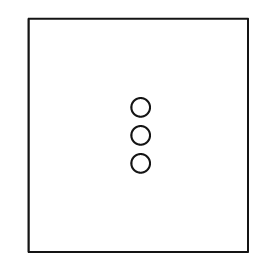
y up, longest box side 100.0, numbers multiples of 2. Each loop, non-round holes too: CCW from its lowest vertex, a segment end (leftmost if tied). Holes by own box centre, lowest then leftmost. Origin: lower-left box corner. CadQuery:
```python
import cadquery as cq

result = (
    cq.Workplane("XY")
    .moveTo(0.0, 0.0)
    .lineTo(94.0, 0.0)
    .lineTo(94.0, 100.0)
    .lineTo(0.0, 100.0)
    .close()
    .moveTo(48.0, 38.0)
    .circle(4.0)
    .moveTo(48.0, 50.0)
    .circle(4.0)
    .moveTo(48.0, 62.0)
    .circle(4.0)
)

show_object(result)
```